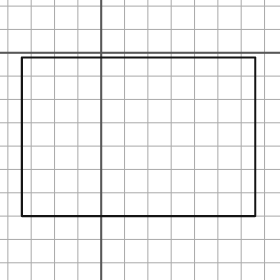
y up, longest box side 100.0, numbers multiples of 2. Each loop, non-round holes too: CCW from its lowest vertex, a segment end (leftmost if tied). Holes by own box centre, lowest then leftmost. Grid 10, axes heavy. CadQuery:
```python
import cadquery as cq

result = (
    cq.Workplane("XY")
    .moveTo(-34.0, -70.0)
    .lineTo(66.0, -70.0)
    .lineTo(66.0, -2.0)
    .lineTo(-34.0, -2.0)
    .close()
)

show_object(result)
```